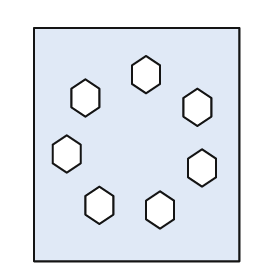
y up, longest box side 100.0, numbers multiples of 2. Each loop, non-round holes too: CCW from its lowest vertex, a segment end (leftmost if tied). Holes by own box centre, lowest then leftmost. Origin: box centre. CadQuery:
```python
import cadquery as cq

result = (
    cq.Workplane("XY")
    .moveTo(-44.0, -50.0)
    .lineTo(44.0, -50.0)
    .lineTo(44.0, 50.0)
    .lineTo(-44.0, 50.0)
    .close()
    .moveTo(10.0, -36.0)
    .lineTo(16.0, -32.0)
    .lineTo(16.0, -24.0)
    .lineTo(10.0, -20.0)
    .lineTo(4.0, -24.0)
    .lineTo(4.0, -32.0)
    .close()
    .moveTo(-16.0, -34.0)
    .lineTo(-10.0, -30.0)
    .lineTo(-10.0, -22.0)
    .lineTo(-16.0, -18.0)
    .lineTo(-22.0, -22.0)
    .lineTo(-22.0, -30.0)
    .close()
    .moveTo(28.0, -18.0)
    .lineTo(34.0, -14.0)
    .lineTo(34.0, -6.0)
    .lineTo(28.0, -2.0)
    .lineTo(22.0, -6.0)
    .lineTo(22.0, -14.0)
    .close()
    .moveTo(-30.0, -12.0)
    .lineTo(-24.0, -8.0)
    .lineTo(-24.0, 0.0)
    .lineTo(-30.0, 4.0)
    .lineTo(-36.0, 0.0)
    .lineTo(-36.0, -8.0)
    .close()
    .moveTo(26.0, 8.0)
    .lineTo(32.0, 12.0)
    .lineTo(32.0, 20.0)
    .lineTo(26.0, 24.0)
    .lineTo(20.0, 20.0)
    .lineTo(20.0, 12.0)
    .close()
    .moveTo(-22.0, 12.0)
    .lineTo(-16.0, 16.0)
    .lineTo(-16.0, 24.0)
    .lineTo(-22.0, 28.0)
    .lineTo(-28.0, 24.0)
    .lineTo(-28.0, 16.0)
    .close()
    .moveTo(4.0, 22.0)
    .lineTo(10.0, 26.0)
    .lineTo(10.0, 34.0)
    .lineTo(4.0, 38.0)
    .lineTo(-2.0, 34.0)
    .lineTo(-2.0, 26.0)
    .close()
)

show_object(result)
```